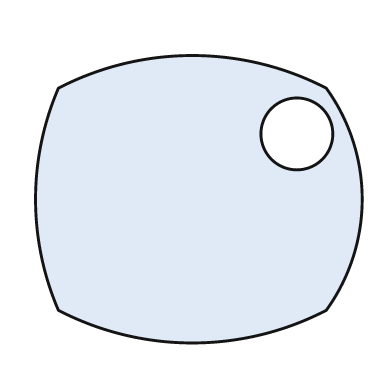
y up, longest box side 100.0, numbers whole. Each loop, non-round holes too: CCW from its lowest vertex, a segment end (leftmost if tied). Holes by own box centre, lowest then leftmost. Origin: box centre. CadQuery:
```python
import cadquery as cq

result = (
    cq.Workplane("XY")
    .moveTo(-43.0, -34.0)
    .threePointArc((-2.0, -44.0), (39.0, -34.0))
    .threePointArc((50.0, 0.0), (39.0, 34.0))
    .threePointArc((-2.0, 44.0), (-43.0, 34.0))
    .threePointArc((-50.0, 0.0), (-43.0, -34.0))
    .close()
    .moveTo(30.0, 20.0)
    .circle(11.0)
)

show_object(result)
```